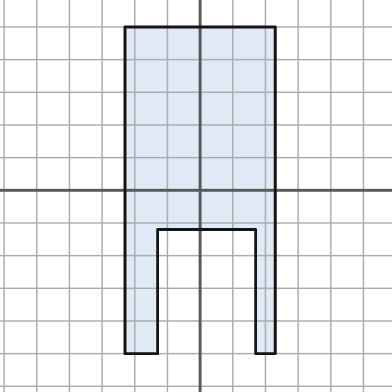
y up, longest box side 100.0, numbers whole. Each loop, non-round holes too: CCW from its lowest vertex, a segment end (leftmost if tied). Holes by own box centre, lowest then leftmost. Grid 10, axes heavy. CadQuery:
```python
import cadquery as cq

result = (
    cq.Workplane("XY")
    .moveTo(-23.0, -50.0)
    .lineTo(-13.0, -50.0)
    .lineTo(-13.0, -12.0)
    .lineTo(17.0, -12.0)
    .lineTo(17.0, -50.0)
    .lineTo(23.0, -50.0)
    .lineTo(23.0, 50.0)
    .lineTo(-23.0, 50.0)
    .close()
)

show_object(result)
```